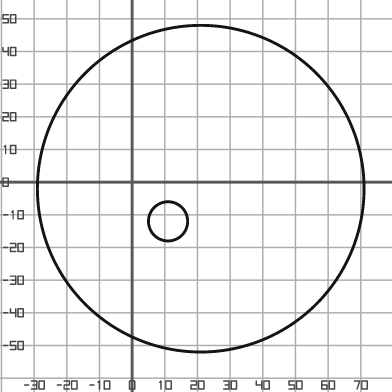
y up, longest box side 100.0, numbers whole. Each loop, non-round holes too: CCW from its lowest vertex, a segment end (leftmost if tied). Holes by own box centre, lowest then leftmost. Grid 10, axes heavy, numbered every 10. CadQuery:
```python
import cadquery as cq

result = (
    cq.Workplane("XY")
    .moveTo(21.0, -2.0)
    .circle(50.0)
    .moveTo(11.0, -12.0)
    .circle(6.0)
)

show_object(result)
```